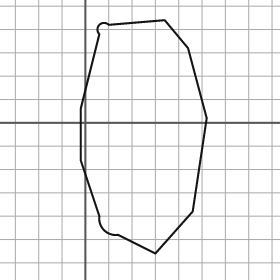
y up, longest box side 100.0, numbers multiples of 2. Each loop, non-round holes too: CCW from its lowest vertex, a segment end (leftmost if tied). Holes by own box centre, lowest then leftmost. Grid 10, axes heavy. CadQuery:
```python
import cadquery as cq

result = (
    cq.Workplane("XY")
    .moveTo(30.0, -56.0)
    .lineTo(46.0, -38.0)
    .lineTo(52.0, 2.0)
    .lineTo(44.0, 32.0)
    .lineTo(34.0, 44.0)
    .lineTo(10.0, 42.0)
    .threePointArc((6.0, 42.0), (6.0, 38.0))
    .lineTo(-2.0, 6.0)
    .lineTo(-2.0, -16.0)
    .lineTo(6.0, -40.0)
    .threePointArc((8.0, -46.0), (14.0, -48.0))
    .close()
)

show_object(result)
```